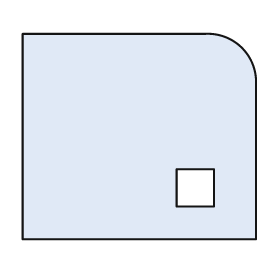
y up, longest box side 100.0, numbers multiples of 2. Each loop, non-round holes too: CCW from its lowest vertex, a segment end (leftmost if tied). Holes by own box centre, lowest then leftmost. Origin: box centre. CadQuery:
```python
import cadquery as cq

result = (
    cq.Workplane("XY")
    .moveTo(-50.0, -44.0)
    .lineTo(50.0, -44.0)
    .lineTo(50.0, 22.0)
    .threePointArc((44.0, 38.0), (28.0, 44.0))
    .lineTo(-50.0, 44.0)
    .close()
    .moveTo(16.0, -30.0)
    .lineTo(32.0, -30.0)
    .lineTo(32.0, -14.0)
    .lineTo(16.0, -14.0)
    .close()
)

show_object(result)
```